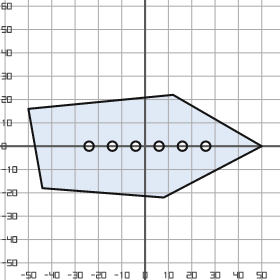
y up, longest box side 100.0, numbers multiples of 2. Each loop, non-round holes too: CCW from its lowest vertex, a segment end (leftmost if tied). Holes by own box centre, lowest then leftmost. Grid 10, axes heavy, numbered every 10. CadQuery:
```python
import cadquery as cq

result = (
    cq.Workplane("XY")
    .moveTo(8.0, -22.0)
    .lineTo(50.0, 0.0)
    .lineTo(12.0, 22.0)
    .lineTo(-50.0, 16.0)
    .lineTo(-44.0, -18.0)
    .close()
    .moveTo(-24.0, 0.0)
    .circle(2.0)
    .moveTo(-14.0, 0.0)
    .circle(2.0)
    .moveTo(-4.0, 0.0)
    .circle(2.0)
    .moveTo(6.0, 0.0)
    .circle(2.0)
    .moveTo(16.0, 0.0)
    .circle(2.0)
    .moveTo(26.0, 0.0)
    .circle(2.0)
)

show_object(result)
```